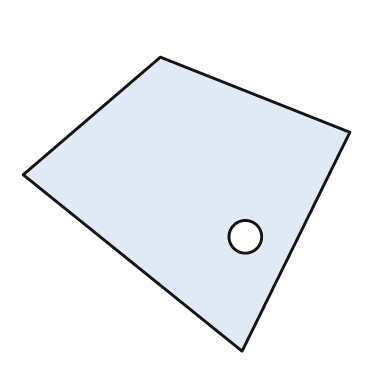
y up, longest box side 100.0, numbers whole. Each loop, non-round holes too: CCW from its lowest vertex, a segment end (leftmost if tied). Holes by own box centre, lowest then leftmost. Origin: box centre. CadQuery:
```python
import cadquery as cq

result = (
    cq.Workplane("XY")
    .moveTo(17.0, -45.0)
    .lineTo(50.0, 22.0)
    .lineTo(-8.0, 45.0)
    .lineTo(-50.0, 9.0)
    .close()
    .moveTo(18.0, -10.0)
    .circle(5.0)
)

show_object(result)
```